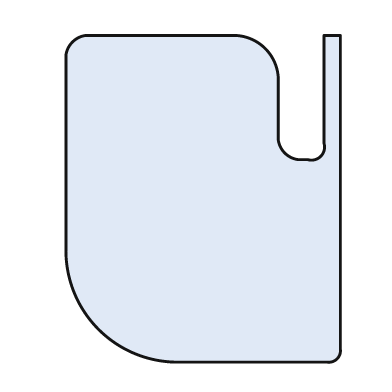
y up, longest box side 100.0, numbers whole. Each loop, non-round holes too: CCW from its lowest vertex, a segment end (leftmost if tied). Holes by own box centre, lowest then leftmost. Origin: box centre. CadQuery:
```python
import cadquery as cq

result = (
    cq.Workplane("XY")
    .moveTo(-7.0, -50.0)
    .lineTo(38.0, -50.0)
    .threePointArc((41.0, -49.0), (42.0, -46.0))
    .lineTo(42.0, 50.0)
    .lineTo(37.0, 50.0)
    .lineTo(37.0, 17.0)
    .threePointArc((36.0, 13.0), (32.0, 12.0))
    .lineTo(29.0, 12.0)
    .threePointArc((25.0, 14.0), (23.0, 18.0))
    .lineTo(23.0, 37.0)
    .threePointArc((19.0, 46.0), (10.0, 50.0))
    .lineTo(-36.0, 50.0)
    .threePointArc((-40.0, 48.0), (-42.0, 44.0))
    .lineTo(-42.0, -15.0)
    .threePointArc((-32.0, -40.0), (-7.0, -50.0))
    .close()
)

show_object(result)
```